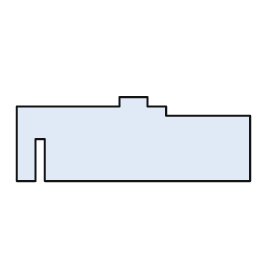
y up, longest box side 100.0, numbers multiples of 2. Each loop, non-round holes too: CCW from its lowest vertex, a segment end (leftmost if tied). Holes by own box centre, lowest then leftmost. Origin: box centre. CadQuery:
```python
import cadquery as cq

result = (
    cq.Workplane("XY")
    .moveTo(-50.0, -18.0)
    .lineTo(-42.0, -18.0)
    .lineTo(-42.0, 0.0)
    .lineTo(-38.0, 0.0)
    .lineTo(-38.0, -18.0)
    .lineTo(50.0, -18.0)
    .lineTo(50.0, 10.0)
    .lineTo(14.0, 10.0)
    .lineTo(14.0, 14.0)
    .lineTo(6.0, 14.0)
    .lineTo(6.0, 18.0)
    .lineTo(-6.0, 18.0)
    .lineTo(-6.0, 14.0)
    .lineTo(-50.0, 14.0)
    .close()
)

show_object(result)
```